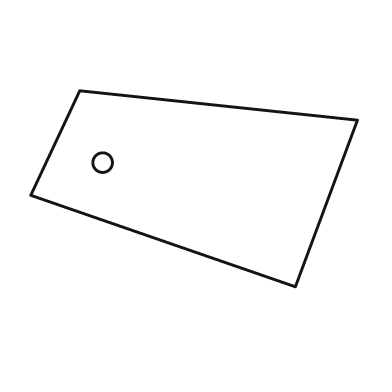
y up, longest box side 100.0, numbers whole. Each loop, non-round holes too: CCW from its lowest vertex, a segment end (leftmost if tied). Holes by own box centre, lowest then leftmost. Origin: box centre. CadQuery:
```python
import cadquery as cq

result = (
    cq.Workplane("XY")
    .moveTo(31.0, -30.0)
    .lineTo(50.0, 21.0)
    .lineTo(-35.0, 30.0)
    .lineTo(-50.0, -2.0)
    .close()
    .moveTo(-28.0, 8.0)
    .circle(3.0)
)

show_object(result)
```